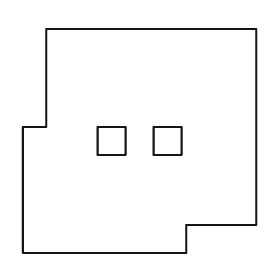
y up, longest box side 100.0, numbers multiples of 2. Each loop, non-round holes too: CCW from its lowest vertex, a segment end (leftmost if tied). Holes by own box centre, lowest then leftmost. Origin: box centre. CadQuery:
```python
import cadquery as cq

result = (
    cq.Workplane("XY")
    .moveTo(-50.0, -48.0)
    .lineTo(20.0, -48.0)
    .lineTo(20.0, -36.0)
    .lineTo(50.0, -36.0)
    .lineTo(50.0, 48.0)
    .lineTo(-40.0, 48.0)
    .lineTo(-40.0, 6.0)
    .lineTo(-50.0, 6.0)
    .close()
    .moveTo(-18.0, -6.0)
    .lineTo(-6.0, -6.0)
    .lineTo(-6.0, 6.0)
    .lineTo(-18.0, 6.0)
    .close()
    .moveTo(6.0, -6.0)
    .lineTo(18.0, -6.0)
    .lineTo(18.0, 6.0)
    .lineTo(6.0, 6.0)
    .close()
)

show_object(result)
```